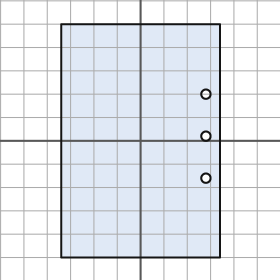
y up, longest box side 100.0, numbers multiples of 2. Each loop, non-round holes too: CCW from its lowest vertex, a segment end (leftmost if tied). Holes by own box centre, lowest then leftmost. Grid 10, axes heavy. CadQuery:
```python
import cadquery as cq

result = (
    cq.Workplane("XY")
    .moveTo(-34.0, -50.0)
    .lineTo(34.0, -50.0)
    .lineTo(34.0, 50.0)
    .lineTo(-34.0, 50.0)
    .close()
    .moveTo(28.0, -16.0)
    .circle(2.0)
    .moveTo(28.0, 2.0)
    .circle(2.0)
    .moveTo(28.0, 20.0)
    .circle(2.0)
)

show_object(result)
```